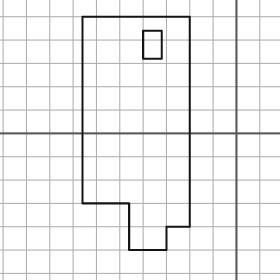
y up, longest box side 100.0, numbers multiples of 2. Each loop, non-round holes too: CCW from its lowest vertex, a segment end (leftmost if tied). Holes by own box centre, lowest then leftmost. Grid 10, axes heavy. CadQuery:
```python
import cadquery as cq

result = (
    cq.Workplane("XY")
    .moveTo(-46.0, -50.0)
    .lineTo(-30.0, -50.0)
    .lineTo(-30.0, -40.0)
    .lineTo(-20.0, -40.0)
    .lineTo(-20.0, 50.0)
    .lineTo(-66.0, 50.0)
    .lineTo(-66.0, -30.0)
    .lineTo(-46.0, -30.0)
    .close()
    .moveTo(-40.0, 32.0)
    .lineTo(-32.0, 32.0)
    .lineTo(-32.0, 44.0)
    .lineTo(-40.0, 44.0)
    .close()
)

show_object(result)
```